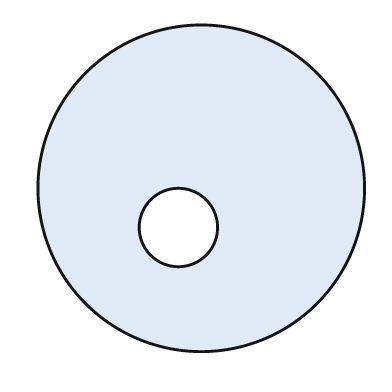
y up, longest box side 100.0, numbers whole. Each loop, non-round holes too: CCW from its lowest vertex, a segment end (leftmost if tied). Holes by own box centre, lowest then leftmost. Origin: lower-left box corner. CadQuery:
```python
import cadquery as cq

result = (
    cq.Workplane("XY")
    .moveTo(50.0, 50.0)
    .circle(50.0)
    .moveTo(43.0, 38.0)
    .circle(12.0)
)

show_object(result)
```